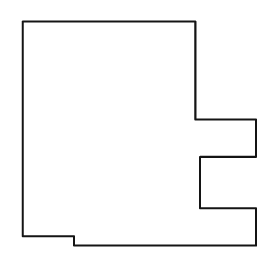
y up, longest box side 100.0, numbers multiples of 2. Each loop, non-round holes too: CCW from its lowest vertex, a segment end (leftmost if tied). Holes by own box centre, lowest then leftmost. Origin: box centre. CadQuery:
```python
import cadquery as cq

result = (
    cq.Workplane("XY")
    .moveTo(-28.0, -48.0)
    .lineTo(50.0, -48.0)
    .lineTo(50.0, -32.0)
    .lineTo(26.0, -32.0)
    .lineTo(26.0, -10.0)
    .lineTo(50.0, -10.0)
    .lineTo(50.0, 6.0)
    .lineTo(24.0, 6.0)
    .lineTo(24.0, 48.0)
    .lineTo(-50.0, 48.0)
    .lineTo(-50.0, -44.0)
    .lineTo(-28.0, -44.0)
    .close()
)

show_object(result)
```